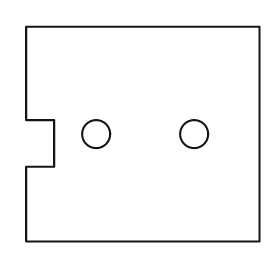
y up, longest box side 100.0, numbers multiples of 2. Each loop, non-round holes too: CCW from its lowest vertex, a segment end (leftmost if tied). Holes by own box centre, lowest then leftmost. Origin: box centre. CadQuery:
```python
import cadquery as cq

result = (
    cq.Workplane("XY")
    .moveTo(-50.0, -46.0)
    .lineTo(50.0, -46.0)
    .lineTo(50.0, 46.0)
    .lineTo(-50.0, 46.0)
    .lineTo(-50.0, 6.0)
    .lineTo(-38.0, 6.0)
    .lineTo(-38.0, -14.0)
    .lineTo(-50.0, -14.0)
    .close()
    .moveTo(-20.0, 0.0)
    .circle(6.0)
    .moveTo(22.0, 0.0)
    .circle(6.0)
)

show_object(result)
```